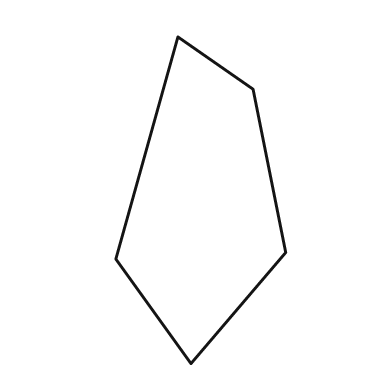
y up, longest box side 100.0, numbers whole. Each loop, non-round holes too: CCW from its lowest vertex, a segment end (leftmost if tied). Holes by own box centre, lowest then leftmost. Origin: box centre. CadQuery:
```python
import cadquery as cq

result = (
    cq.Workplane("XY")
    .moveTo(-3.0, -50.0)
    .lineTo(26.0, -16.0)
    .lineTo(16.0, 34.0)
    .lineTo(-7.0, 50.0)
    .lineTo(-26.0, -18.0)
    .close()
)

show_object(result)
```